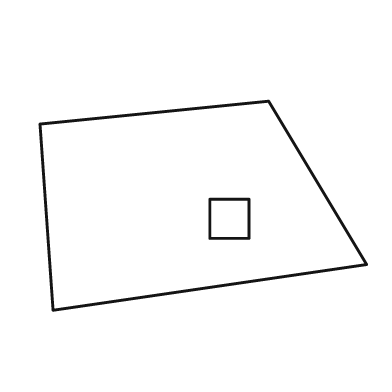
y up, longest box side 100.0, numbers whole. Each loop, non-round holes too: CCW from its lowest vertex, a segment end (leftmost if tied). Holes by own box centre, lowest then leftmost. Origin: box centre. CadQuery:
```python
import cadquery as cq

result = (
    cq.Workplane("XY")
    .moveTo(-46.0, -32.0)
    .lineTo(50.0, -18.0)
    .lineTo(20.0, 32.0)
    .lineTo(-50.0, 25.0)
    .close()
    .moveTo(2.0, -10.0)
    .lineTo(14.0, -10.0)
    .lineTo(14.0, 2.0)
    .lineTo(2.0, 2.0)
    .close()
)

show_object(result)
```